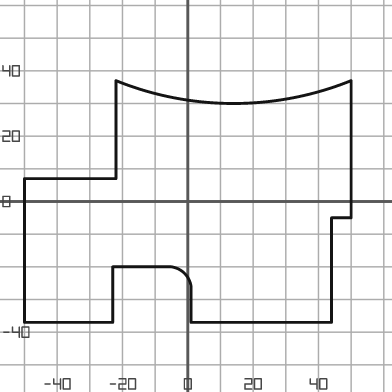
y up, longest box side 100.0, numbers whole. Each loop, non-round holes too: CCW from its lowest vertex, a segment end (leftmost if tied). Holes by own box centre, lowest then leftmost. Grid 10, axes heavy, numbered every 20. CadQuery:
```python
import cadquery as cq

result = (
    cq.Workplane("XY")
    .moveTo(-50.0, -37.0)
    .lineTo(-23.0, -37.0)
    .lineTo(-23.0, -20.0)
    .lineTo(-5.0, -20.0)
    .threePointArc((-1.0, -22.0), (1.0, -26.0))
    .lineTo(1.0, -37.0)
    .lineTo(44.0, -37.0)
    .lineTo(44.0, -5.0)
    .lineTo(50.0, -5.0)
    .lineTo(50.0, 37.0)
    .threePointArc((14.0, 30.0), (-22.0, 37.0))
    .lineTo(-22.0, 7.0)
    .lineTo(-50.0, 7.0)
    .close()
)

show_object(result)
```